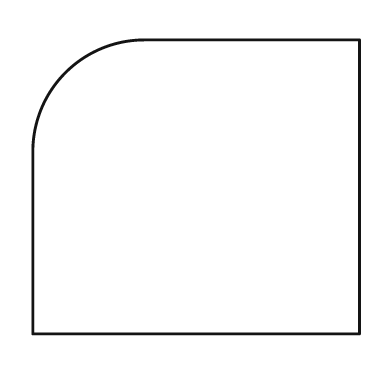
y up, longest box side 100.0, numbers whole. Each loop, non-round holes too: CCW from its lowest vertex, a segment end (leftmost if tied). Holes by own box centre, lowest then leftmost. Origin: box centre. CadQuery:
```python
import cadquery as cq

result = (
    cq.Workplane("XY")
    .moveTo(-50.0, -45.0)
    .lineTo(50.0, -45.0)
    .lineTo(50.0, 45.0)
    .lineTo(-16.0, 45.0)
    .threePointArc((-40.0, 35.0), (-50.0, 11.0))
    .close()
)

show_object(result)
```